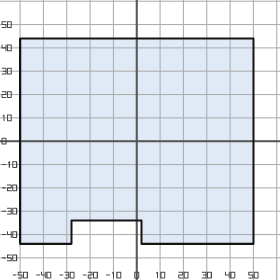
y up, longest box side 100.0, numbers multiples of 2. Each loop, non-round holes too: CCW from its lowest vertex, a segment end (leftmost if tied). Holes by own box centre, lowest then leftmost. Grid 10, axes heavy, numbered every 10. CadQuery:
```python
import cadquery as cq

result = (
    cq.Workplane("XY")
    .moveTo(-50.0, -44.0)
    .lineTo(-28.0, -44.0)
    .lineTo(-28.0, -34.0)
    .lineTo(2.0, -34.0)
    .lineTo(2.0, -44.0)
    .lineTo(50.0, -44.0)
    .lineTo(50.0, 44.0)
    .lineTo(-50.0, 44.0)
    .close()
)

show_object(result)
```